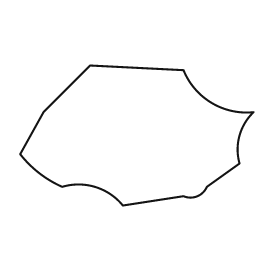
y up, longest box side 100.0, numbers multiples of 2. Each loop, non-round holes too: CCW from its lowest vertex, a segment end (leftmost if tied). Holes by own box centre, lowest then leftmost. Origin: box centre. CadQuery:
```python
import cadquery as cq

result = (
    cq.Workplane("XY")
    .moveTo(-6.0, -30.0)
    .lineTo(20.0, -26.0)
    .threePointArc((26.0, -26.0), (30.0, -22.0))
    .lineTo(44.0, -12.0)
    .threePointArc((44.0, 0.0), (50.0, 10.0))
    .threePointArc((32.0, 14.0), (20.0, 28.0))
    .lineTo(-20.0, 30.0)
    .lineTo(-40.0, 10.0)
    .lineTo(-50.0, -8.0)
    .threePointArc((-42.0, -16.0), (-32.0, -22.0))
    .threePointArc((-18.0, -22.0), (-6.0, -30.0))
    .close()
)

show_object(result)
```